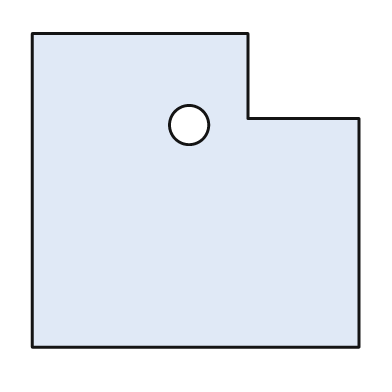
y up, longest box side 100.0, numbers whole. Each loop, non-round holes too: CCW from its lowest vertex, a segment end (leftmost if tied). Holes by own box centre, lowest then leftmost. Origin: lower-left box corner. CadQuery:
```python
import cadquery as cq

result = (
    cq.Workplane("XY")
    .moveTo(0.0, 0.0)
    .lineTo(100.0, 0.0)
    .lineTo(100.0, 70.0)
    .lineTo(66.0, 70.0)
    .lineTo(66.0, 96.0)
    .lineTo(0.0, 96.0)
    .close()
    .moveTo(48.0, 68.0)
    .circle(6.0)
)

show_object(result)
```